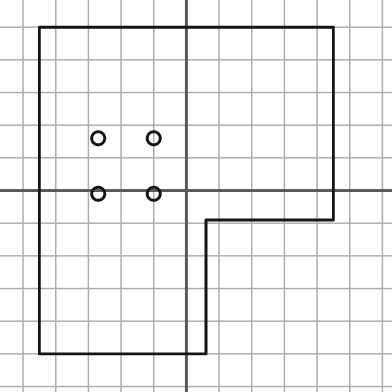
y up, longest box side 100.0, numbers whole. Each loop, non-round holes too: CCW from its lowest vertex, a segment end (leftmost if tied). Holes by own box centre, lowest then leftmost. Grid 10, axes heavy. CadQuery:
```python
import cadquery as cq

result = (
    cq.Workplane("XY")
    .moveTo(-45.0, -50.0)
    .lineTo(6.0, -50.0)
    .lineTo(6.0, -9.0)
    .lineTo(45.0, -9.0)
    .lineTo(45.0, 50.0)
    .lineTo(-45.0, 50.0)
    .close()
    .moveTo(-27.0, -1.0)
    .circle(2.0)
    .moveTo(-10.0, -1.0)
    .circle(2.0)
    .moveTo(-27.0, 16.0)
    .circle(2.0)
    .moveTo(-10.0, 16.0)
    .circle(2.0)
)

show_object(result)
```